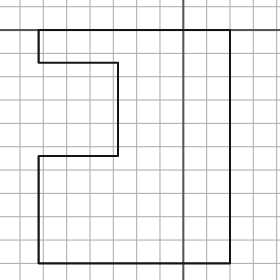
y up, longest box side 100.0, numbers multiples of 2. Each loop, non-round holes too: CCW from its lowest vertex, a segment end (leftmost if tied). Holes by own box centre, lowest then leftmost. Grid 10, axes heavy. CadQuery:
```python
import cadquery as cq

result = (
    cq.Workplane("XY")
    .moveTo(-62.0, -100.0)
    .lineTo(20.0, -100.0)
    .lineTo(20.0, 0.0)
    .lineTo(-62.0, 0.0)
    .lineTo(-62.0, -14.0)
    .lineTo(-28.0, -14.0)
    .lineTo(-28.0, -54.0)
    .lineTo(-62.0, -54.0)
    .close()
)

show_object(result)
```